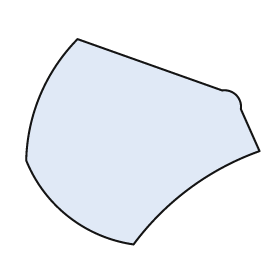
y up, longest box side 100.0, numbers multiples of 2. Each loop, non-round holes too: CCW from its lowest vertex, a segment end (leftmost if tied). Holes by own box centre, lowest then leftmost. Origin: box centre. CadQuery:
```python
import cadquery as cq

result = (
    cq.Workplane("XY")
    .moveTo(-4.0, -44.0)
    .threePointArc((20.0, -20.0), (50.0, -4.0))
    .lineTo(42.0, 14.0)
    .threePointArc((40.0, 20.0), (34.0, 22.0))
    .lineTo(-28.0, 44.0)
    .threePointArc((-44.0, 20.0), (-50.0, -8.0))
    .threePointArc((-32.0, -32.0), (-4.0, -44.0))
    .close()
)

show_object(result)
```